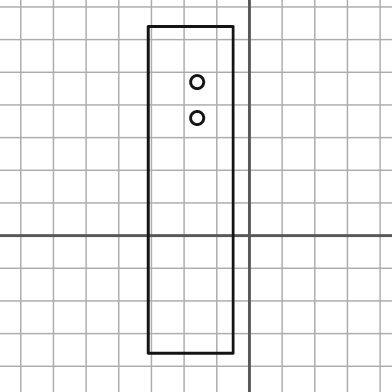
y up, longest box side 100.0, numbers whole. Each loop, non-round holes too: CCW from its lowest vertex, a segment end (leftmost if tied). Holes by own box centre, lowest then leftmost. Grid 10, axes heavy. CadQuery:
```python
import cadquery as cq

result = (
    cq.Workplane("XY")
    .moveTo(-31.0, -36.0)
    .lineTo(-5.0, -36.0)
    .lineTo(-5.0, 64.0)
    .lineTo(-31.0, 64.0)
    .close()
    .moveTo(-16.0, 36.0)
    .circle(2.0)
    .moveTo(-16.0, 47.0)
    .circle(2.0)
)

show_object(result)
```